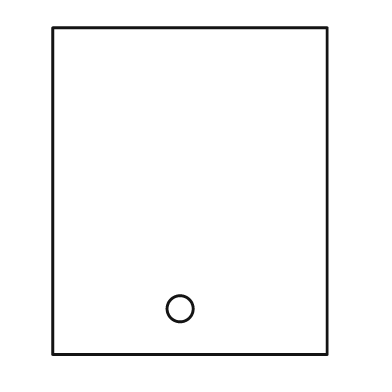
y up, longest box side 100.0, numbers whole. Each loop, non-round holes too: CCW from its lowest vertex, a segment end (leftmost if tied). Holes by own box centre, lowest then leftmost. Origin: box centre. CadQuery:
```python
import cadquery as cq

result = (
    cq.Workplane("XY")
    .moveTo(-42.0, -50.0)
    .lineTo(42.0, -50.0)
    .lineTo(42.0, 50.0)
    .lineTo(-42.0, 50.0)
    .close()
    .moveTo(-3.0, -36.0)
    .circle(4.0)
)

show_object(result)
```